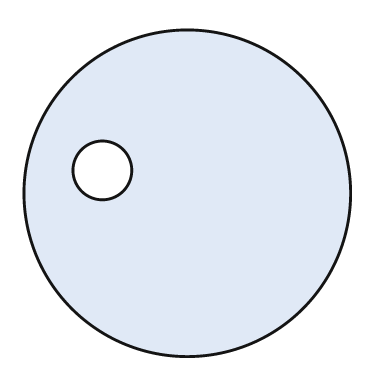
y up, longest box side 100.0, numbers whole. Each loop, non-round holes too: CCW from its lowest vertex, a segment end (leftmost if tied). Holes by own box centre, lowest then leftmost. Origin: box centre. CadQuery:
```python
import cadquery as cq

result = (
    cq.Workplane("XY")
    .moveTo(0.0, 0.0)
    .circle(50.0)
    .moveTo(-26.0, 7.0)
    .circle(9.0)
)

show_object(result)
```